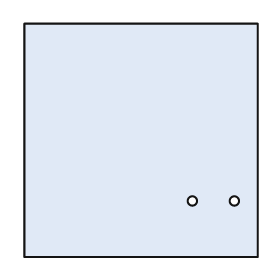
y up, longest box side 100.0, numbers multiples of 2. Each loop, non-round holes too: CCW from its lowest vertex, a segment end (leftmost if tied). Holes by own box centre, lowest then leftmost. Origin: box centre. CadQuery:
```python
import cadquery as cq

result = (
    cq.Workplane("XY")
    .moveTo(-50.0, -50.0)
    .lineTo(50.0, -50.0)
    .lineTo(50.0, 50.0)
    .lineTo(-50.0, 50.0)
    .close()
    .moveTo(22.0, -26.0)
    .circle(2.0)
    .moveTo(40.0, -26.0)
    .circle(2.0)
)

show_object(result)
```